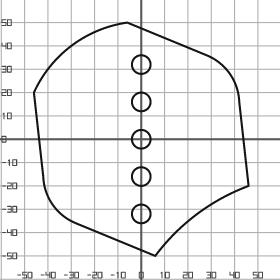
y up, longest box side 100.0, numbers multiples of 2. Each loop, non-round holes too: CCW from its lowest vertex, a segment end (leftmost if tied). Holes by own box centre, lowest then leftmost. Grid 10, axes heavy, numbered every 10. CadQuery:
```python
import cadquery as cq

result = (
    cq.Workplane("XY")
    .moveTo(6.0, -50.0)
    .threePointArc((24.0, -32.0), (46.0, -20.0))
    .lineTo(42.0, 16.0)
    .threePointArc((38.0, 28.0), (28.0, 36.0))
    .lineTo(-6.0, 50.0)
    .threePointArc((-30.0, 40.0), (-46.0, 20.0))
    .lineTo(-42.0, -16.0)
    .threePointArc((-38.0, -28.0), (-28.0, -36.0))
    .close()
    .moveTo(0.0, -32.0)
    .circle(4.0)
    .moveTo(0.0, -16.0)
    .circle(4.0)
    .moveTo(0.0, 0.0)
    .circle(4.0)
    .moveTo(0.0, 16.0)
    .circle(4.0)
    .moveTo(0.0, 32.0)
    .circle(4.0)
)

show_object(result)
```